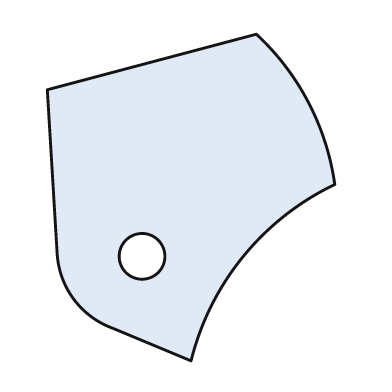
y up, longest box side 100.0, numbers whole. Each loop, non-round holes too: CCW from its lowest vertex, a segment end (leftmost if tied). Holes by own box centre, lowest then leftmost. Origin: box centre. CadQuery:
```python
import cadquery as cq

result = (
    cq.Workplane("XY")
    .moveTo(0.0, -50.0)
    .threePointArc((16.0, -18.0), (44.0, 4.0))
    .threePointArc((36.0, 29.0), (20.0, 50.0))
    .lineTo(-44.0, 33.0)
    .lineTo(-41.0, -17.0)
    .threePointArc((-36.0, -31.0), (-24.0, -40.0))
    .close()
    .moveTo(-15.0, -18.0)
    .circle(7.0)
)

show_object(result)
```